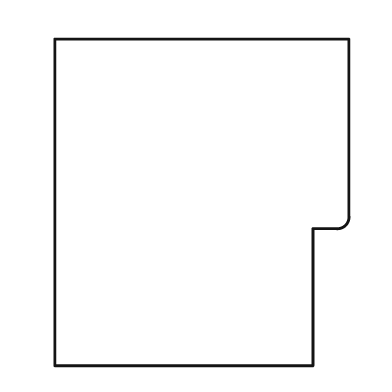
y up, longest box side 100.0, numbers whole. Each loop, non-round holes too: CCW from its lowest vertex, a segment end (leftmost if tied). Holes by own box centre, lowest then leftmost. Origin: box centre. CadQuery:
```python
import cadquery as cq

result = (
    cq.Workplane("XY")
    .moveTo(-45.0, -50.0)
    .lineTo(34.0, -50.0)
    .lineTo(34.0, -8.0)
    .lineTo(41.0, -8.0)
    .threePointArc((44.0, -7.0), (45.0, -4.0))
    .lineTo(45.0, 50.0)
    .lineTo(-45.0, 50.0)
    .close()
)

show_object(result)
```